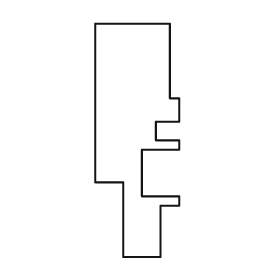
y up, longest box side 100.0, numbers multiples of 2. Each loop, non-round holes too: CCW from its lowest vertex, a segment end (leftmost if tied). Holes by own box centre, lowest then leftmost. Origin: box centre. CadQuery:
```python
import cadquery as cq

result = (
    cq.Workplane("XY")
    .moveTo(-6.0, -50.0)
    .lineTo(10.0, -50.0)
    .lineTo(10.0, -28.0)
    .lineTo(18.0, -28.0)
    .lineTo(18.0, -24.0)
    .lineTo(2.0, -24.0)
    .lineTo(2.0, -4.0)
    .lineTo(18.0, -4.0)
    .lineTo(18.0, 0.0)
    .lineTo(8.0, 0.0)
    .lineTo(8.0, 8.0)
    .lineTo(18.0, 8.0)
    .lineTo(18.0, 18.0)
    .lineTo(14.0, 18.0)
    .lineTo(14.0, 50.0)
    .lineTo(-18.0, 50.0)
    .lineTo(-18.0, -18.0)
    .lineTo(-6.0, -18.0)
    .close()
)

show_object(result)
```